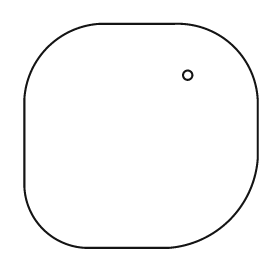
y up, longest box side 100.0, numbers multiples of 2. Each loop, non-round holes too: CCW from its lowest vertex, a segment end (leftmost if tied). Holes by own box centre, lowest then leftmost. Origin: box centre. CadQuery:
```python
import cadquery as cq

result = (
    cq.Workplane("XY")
    .moveTo(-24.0, -48.0)
    .lineTo(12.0, -48.0)
    .threePointArc((38.0, -36.0), (50.0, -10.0))
    .lineTo(50.0, 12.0)
    .threePointArc((40.0, 38.0), (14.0, 48.0))
    .lineTo(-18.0, 48.0)
    .threePointArc((-40.0, 38.0), (-50.0, 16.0))
    .lineTo(-50.0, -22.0)
    .threePointArc((-42.0, -40.0), (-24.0, -48.0))
    .close()
    .moveTo(20.0, 26.0)
    .circle(2.0)
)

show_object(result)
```